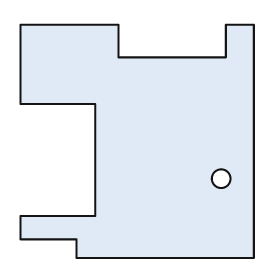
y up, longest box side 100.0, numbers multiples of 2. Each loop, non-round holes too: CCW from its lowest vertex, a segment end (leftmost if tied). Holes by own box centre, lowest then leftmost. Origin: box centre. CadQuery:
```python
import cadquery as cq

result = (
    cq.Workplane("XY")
    .moveTo(-26.0, -50.0)
    .lineTo(50.0, -50.0)
    .lineTo(50.0, 50.0)
    .lineTo(38.0, 50.0)
    .lineTo(38.0, 36.0)
    .lineTo(-8.0, 36.0)
    .lineTo(-8.0, 50.0)
    .lineTo(-50.0, 50.0)
    .lineTo(-50.0, 16.0)
    .lineTo(-18.0, 16.0)
    .lineTo(-18.0, -32.0)
    .lineTo(-50.0, -32.0)
    .lineTo(-50.0, -42.0)
    .lineTo(-26.0, -42.0)
    .close()
    .moveTo(36.0, -16.0)
    .circle(4.0)
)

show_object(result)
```